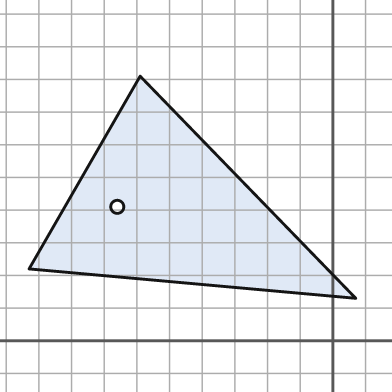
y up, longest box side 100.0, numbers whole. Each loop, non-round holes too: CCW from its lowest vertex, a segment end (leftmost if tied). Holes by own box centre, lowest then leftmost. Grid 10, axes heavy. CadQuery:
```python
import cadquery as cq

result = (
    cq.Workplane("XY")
    .moveTo(7.0, 13.0)
    .lineTo(-59.0, 81.0)
    .lineTo(-93.0, 22.0)
    .close()
    .moveTo(-66.0, 41.0)
    .circle(2.0)
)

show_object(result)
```